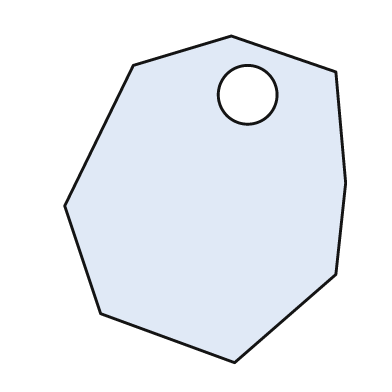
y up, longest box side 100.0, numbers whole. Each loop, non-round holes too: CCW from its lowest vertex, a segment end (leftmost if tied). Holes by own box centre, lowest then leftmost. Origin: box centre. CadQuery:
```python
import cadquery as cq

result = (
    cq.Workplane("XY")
    .moveTo(9.0, -50.0)
    .lineTo(40.0, -23.0)
    .lineTo(43.0, 5.0)
    .lineTo(40.0, 39.0)
    .lineTo(8.0, 50.0)
    .lineTo(-22.0, 41.0)
    .lineTo(-43.0, -2.0)
    .lineTo(-32.0, -35.0)
    .close()
    .moveTo(13.0, 32.0)
    .circle(9.0)
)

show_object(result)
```